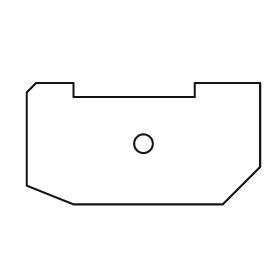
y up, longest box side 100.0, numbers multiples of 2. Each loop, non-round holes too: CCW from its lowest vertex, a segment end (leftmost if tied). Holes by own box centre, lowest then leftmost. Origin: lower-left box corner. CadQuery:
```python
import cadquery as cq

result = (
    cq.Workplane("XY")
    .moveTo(20.0, 0.0)
    .lineTo(84.0, 0.0)
    .lineTo(100.0, 16.0)
    .lineTo(100.0, 52.0)
    .lineTo(72.0, 52.0)
    .lineTo(72.0, 46.0)
    .lineTo(20.0, 46.0)
    .lineTo(20.0, 52.0)
    .lineTo(4.0, 52.0)
    .lineTo(0.0, 48.0)
    .lineTo(0.0, 8.0)
    .close()
    .moveTo(50.0, 26.0)
    .circle(4.0)
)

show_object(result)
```